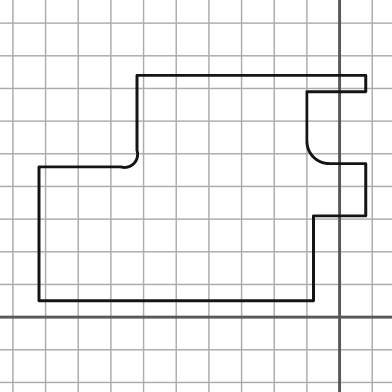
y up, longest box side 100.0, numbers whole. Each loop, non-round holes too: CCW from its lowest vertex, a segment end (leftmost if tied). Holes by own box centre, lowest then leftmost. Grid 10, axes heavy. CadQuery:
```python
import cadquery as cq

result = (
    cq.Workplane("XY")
    .moveTo(-92.0, 5.0)
    .lineTo(-8.0, 5.0)
    .lineTo(-8.0, 31.0)
    .lineTo(8.0, 31.0)
    .lineTo(8.0, 47.0)
    .lineTo(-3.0, 47.0)
    .threePointArc((-8.0, 49.0), (-10.0, 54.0))
    .lineTo(-10.0, 69.0)
    .lineTo(8.0, 69.0)
    .lineTo(8.0, 74.0)
    .lineTo(-62.0, 74.0)
    .lineTo(-62.0, 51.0)
    .threePointArc((-63.0, 47.0), (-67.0, 46.0))
    .lineTo(-92.0, 46.0)
    .close()
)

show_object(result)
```